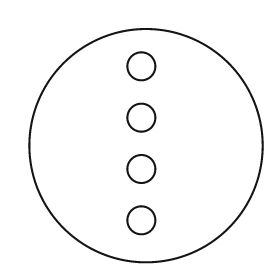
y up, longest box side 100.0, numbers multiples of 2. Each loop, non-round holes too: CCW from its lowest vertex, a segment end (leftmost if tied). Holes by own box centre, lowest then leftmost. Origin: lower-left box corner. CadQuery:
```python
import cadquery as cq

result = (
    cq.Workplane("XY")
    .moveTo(50.0, 50.0)
    .circle(50.0)
    .moveTo(48.0, 18.0)
    .circle(6.0)
    .moveTo(48.0, 40.0)
    .circle(6.0)
    .moveTo(48.0, 62.0)
    .circle(6.0)
    .moveTo(48.0, 84.0)
    .circle(6.0)
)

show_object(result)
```